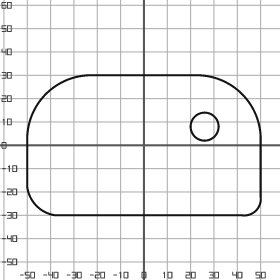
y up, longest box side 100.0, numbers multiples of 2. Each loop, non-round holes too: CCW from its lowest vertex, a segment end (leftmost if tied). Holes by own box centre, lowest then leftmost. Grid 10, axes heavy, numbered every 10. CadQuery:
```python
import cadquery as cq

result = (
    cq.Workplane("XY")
    .moveTo(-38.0, -30.0)
    .lineTo(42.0, -30.0)
    .threePointArc((48.0, -28.0), (50.0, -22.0))
    .lineTo(50.0, 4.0)
    .threePointArc((42.0, 22.0), (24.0, 30.0))
    .lineTo(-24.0, 30.0)
    .threePointArc((-42.0, 22.0), (-50.0, 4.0))
    .lineTo(-50.0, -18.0)
    .threePointArc((-46.0, -26.0), (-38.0, -30.0))
    .close()
    .moveTo(26.0, 8.0)
    .circle(6.0)
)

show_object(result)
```